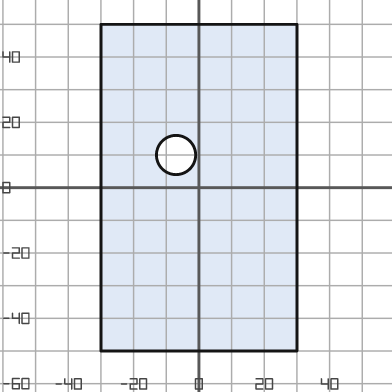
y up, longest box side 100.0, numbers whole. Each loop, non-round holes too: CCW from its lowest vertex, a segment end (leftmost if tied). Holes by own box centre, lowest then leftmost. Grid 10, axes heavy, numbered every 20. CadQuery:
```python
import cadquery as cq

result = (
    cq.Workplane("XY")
    .moveTo(-30.0, -50.0)
    .lineTo(30.0, -50.0)
    .lineTo(30.0, 50.0)
    .lineTo(-30.0, 50.0)
    .close()
    .moveTo(-7.0, 10.0)
    .circle(6.0)
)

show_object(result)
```